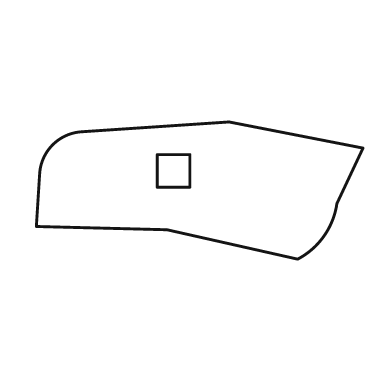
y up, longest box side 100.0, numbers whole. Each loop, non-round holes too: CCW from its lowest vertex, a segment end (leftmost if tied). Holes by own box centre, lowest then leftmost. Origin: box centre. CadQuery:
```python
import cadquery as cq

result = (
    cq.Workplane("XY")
    .moveTo(30.0, -21.0)
    .threePointArc((38.0, -14.0), (42.0, -4.0))
    .lineTo(50.0, 13.0)
    .lineTo(9.0, 21.0)
    .lineTo(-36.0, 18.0)
    .threePointArc((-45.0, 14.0), (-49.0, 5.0))
    .lineTo(-50.0, -11.0)
    .lineTo(-10.0, -12.0)
    .close()
    .moveTo(-13.0, 1.0)
    .lineTo(-3.0, 1.0)
    .lineTo(-3.0, 11.0)
    .lineTo(-13.0, 11.0)
    .close()
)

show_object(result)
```